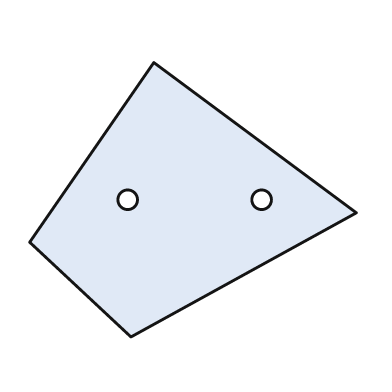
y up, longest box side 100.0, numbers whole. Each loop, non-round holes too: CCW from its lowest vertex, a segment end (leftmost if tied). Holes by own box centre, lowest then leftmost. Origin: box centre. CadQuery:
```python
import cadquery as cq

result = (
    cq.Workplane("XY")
    .moveTo(-19.0, -42.0)
    .lineTo(50.0, -4.0)
    .lineTo(-12.0, 42.0)
    .lineTo(-50.0, -13.0)
    .close()
    .moveTo(-20.0, 0.0)
    .circle(3.0)
    .moveTo(21.0, 0.0)
    .circle(3.0)
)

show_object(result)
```